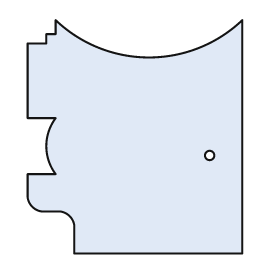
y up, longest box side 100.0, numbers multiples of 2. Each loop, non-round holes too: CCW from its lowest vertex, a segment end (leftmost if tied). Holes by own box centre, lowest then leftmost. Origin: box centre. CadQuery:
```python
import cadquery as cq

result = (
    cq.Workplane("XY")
    .moveTo(-26.0, -50.0)
    .lineTo(46.0, -50.0)
    .lineTo(46.0, 50.0)
    .threePointArc((6.0, 34.0), (-34.0, 50.0))
    .lineTo(-34.0, 44.0)
    .lineTo(-38.0, 44.0)
    .lineTo(-38.0, 40.0)
    .lineTo(-46.0, 40.0)
    .lineTo(-46.0, 8.0)
    .lineTo(-34.0, 8.0)
    .threePointArc((-38.0, -4.0), (-34.0, -16.0))
    .lineTo(-46.0, -16.0)
    .lineTo(-46.0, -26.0)
    .threePointArc((-44.0, -30.0), (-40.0, -32.0))
    .lineTo(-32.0, -32.0)
    .threePointArc((-28.0, -34.0), (-26.0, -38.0))
    .close()
    .moveTo(32.0, -8.0)
    .circle(2.0)
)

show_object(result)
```